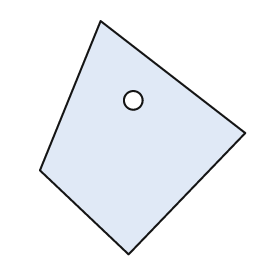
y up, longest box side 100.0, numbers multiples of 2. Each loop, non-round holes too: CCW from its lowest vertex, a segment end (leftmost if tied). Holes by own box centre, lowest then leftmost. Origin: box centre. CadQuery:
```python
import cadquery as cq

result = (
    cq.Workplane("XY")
    .moveTo(-6.0, -50.0)
    .lineTo(44.0, 2.0)
    .lineTo(-18.0, 50.0)
    .lineTo(-44.0, -14.0)
    .close()
    .moveTo(-4.0, 16.0)
    .circle(4.0)
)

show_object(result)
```